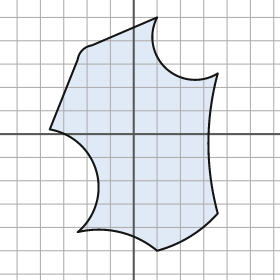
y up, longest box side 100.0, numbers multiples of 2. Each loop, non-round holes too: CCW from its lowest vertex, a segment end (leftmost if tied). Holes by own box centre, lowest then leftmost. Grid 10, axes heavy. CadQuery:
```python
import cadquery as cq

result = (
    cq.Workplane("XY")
    .moveTo(10.0, -50.0)
    .threePointArc((24.0, -44.0), (36.0, -34.0))
    .threePointArc((32.0, -4.0), (36.0, 26.0))
    .threePointArc((14.0, 28.0), (10.0, 50.0))
    .lineTo(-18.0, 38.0)
    .threePointArc((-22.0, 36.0), (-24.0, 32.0))
    .lineTo(-36.0, 2.0)
    .threePointArc((-16.0, -16.0), (-24.0, -42.0))
    .threePointArc((-6.0, -42.0), (10.0, -50.0))
    .close()
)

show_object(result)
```